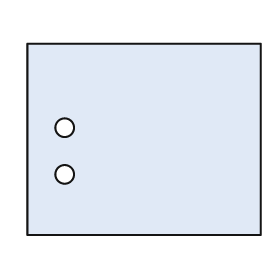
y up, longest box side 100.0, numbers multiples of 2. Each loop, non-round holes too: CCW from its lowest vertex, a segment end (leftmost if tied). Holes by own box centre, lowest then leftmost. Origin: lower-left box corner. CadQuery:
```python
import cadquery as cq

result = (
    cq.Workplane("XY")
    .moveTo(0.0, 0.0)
    .lineTo(100.0, 0.0)
    .lineTo(100.0, 82.0)
    .lineTo(0.0, 82.0)
    .close()
    .moveTo(16.0, 26.0)
    .circle(4.0)
    .moveTo(16.0, 46.0)
    .circle(4.0)
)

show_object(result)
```